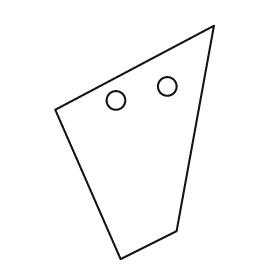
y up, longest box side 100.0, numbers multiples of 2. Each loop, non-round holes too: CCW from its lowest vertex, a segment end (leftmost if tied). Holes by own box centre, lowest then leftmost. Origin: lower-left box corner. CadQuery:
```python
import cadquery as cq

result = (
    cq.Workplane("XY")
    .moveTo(28.0, 0.0)
    .lineTo(52.0, 12.0)
    .lineTo(68.0, 100.0)
    .lineTo(0.0, 64.0)
    .close()
    .moveTo(26.0, 68.0)
    .circle(4.0)
    .moveTo(48.0, 74.0)
    .circle(4.0)
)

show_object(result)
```